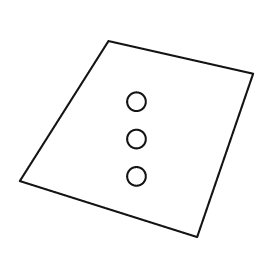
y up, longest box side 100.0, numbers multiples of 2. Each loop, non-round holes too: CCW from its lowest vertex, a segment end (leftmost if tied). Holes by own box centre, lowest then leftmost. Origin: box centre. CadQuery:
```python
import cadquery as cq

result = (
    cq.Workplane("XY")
    .moveTo(26.0, -42.0)
    .lineTo(50.0, 28.0)
    .lineTo(-12.0, 42.0)
    .lineTo(-50.0, -18.0)
    .close()
    .moveTo(0.0, -16.0)
    .circle(4.0)
    .moveTo(0.0, 0.0)
    .circle(4.0)
    .moveTo(0.0, 16.0)
    .circle(4.0)
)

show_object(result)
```